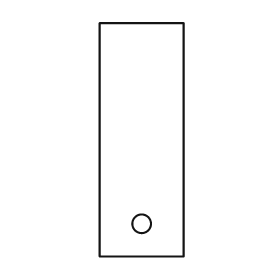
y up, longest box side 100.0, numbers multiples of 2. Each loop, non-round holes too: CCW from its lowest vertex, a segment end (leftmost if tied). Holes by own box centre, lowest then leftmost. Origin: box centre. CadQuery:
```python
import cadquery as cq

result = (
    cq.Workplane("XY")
    .moveTo(-18.0, -50.0)
    .lineTo(18.0, -50.0)
    .lineTo(18.0, 50.0)
    .lineTo(-18.0, 50.0)
    .close()
    .moveTo(0.0, -36.0)
    .circle(4.0)
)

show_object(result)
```